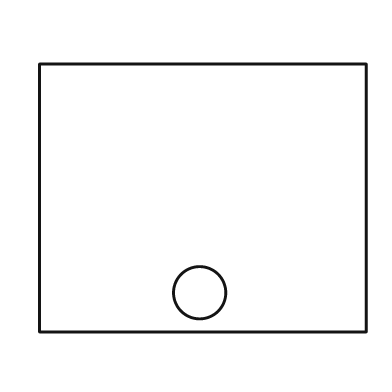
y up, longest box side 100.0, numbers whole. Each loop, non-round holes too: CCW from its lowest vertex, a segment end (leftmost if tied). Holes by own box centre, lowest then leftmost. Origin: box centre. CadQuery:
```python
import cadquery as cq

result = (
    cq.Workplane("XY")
    .moveTo(-50.0, -41.0)
    .lineTo(50.0, -41.0)
    .lineTo(50.0, 41.0)
    .lineTo(-50.0, 41.0)
    .close()
    .moveTo(-1.0, -29.0)
    .circle(8.0)
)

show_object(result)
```